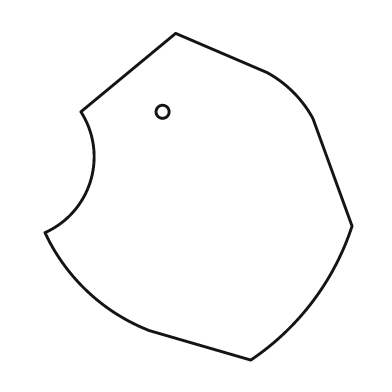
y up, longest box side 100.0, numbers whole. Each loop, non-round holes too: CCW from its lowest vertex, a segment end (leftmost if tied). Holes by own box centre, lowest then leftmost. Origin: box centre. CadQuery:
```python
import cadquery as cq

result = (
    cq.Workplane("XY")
    .moveTo(16.0, -50.0)
    .threePointArc((35.0, -32.0), (47.0, -9.0))
    .lineTo(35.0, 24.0)
    .threePointArc((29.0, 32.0), (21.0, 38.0))
    .lineTo(-7.0, 50.0)
    .lineTo(-36.0, 26.0)
    .threePointArc((-33.0, 5.0), (-47.0, -11.0))
    .threePointArc((-34.0, -29.0), (-15.0, -41.0))
    .close()
    .moveTo(-11.0, 26.0)
    .circle(2.0)
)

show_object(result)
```